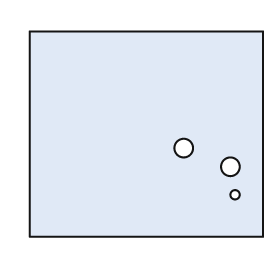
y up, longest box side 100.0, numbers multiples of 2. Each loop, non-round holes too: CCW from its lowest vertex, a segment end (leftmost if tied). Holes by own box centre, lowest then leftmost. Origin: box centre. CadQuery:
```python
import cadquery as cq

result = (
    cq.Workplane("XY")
    .moveTo(-50.0, -44.0)
    .lineTo(50.0, -44.0)
    .lineTo(50.0, 44.0)
    .lineTo(-50.0, 44.0)
    .close()
    .moveTo(38.0, -26.0)
    .circle(2.0)
    .moveTo(36.0, -14.0)
    .circle(4.0)
    .moveTo(16.0, -6.0)
    .circle(4.0)
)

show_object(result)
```